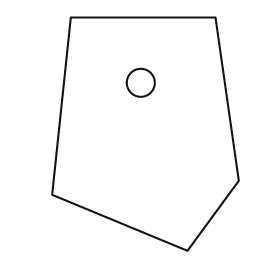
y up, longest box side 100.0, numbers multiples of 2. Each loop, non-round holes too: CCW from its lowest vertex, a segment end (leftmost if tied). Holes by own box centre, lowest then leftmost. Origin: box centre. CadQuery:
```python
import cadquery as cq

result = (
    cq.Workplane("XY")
    .moveTo(18.0, -50.0)
    .lineTo(40.0, -20.0)
    .lineTo(30.0, 50.0)
    .lineTo(-32.0, 50.0)
    .lineTo(-40.0, -26.0)
    .close()
    .moveTo(-2.0, 22.0)
    .circle(6.0)
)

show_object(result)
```